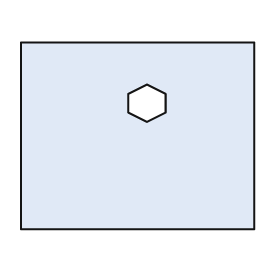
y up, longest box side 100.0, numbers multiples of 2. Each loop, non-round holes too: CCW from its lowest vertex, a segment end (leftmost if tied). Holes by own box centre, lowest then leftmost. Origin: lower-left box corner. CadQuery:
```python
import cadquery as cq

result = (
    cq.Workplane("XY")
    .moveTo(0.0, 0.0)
    .lineTo(100.0, 0.0)
    .lineTo(100.0, 80.0)
    .lineTo(0.0, 80.0)
    .close()
    .moveTo(54.0, 46.0)
    .lineTo(62.0, 50.0)
    .lineTo(62.0, 58.0)
    .lineTo(54.0, 62.0)
    .lineTo(46.0, 58.0)
    .lineTo(46.0, 50.0)
    .close()
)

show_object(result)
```